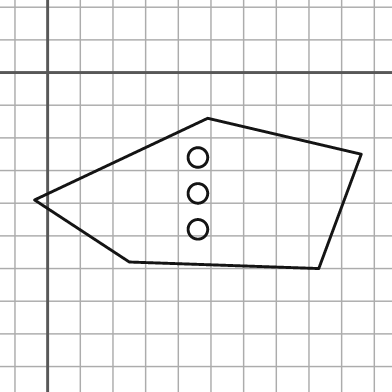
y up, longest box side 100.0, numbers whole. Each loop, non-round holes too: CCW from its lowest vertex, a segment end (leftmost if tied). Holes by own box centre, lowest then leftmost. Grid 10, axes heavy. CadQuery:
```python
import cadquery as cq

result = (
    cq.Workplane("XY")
    .moveTo(83.0, -60.0)
    .lineTo(96.0, -25.0)
    .lineTo(49.0, -14.0)
    .lineTo(-4.0, -39.0)
    .lineTo(25.0, -58.0)
    .close()
    .moveTo(46.0, -48.0)
    .circle(3.0)
    .moveTo(46.0, -37.0)
    .circle(3.0)
    .moveTo(46.0, -26.0)
    .circle(3.0)
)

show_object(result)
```